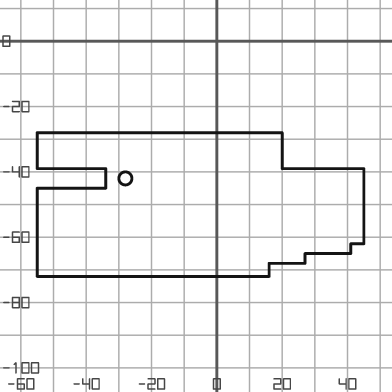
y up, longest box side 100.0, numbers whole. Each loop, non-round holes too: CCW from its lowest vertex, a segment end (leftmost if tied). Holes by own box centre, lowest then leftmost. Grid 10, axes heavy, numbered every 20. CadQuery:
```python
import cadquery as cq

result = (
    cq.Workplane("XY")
    .moveTo(-55.0, -72.0)
    .lineTo(16.0, -72.0)
    .lineTo(16.0, -68.0)
    .lineTo(27.0, -68.0)
    .lineTo(27.0, -65.0)
    .lineTo(41.0, -65.0)
    .lineTo(41.0, -62.0)
    .lineTo(45.0, -62.0)
    .lineTo(45.0, -39.0)
    .lineTo(20.0, -39.0)
    .lineTo(20.0, -28.0)
    .lineTo(-55.0, -28.0)
    .lineTo(-55.0, -39.0)
    .lineTo(-34.0, -39.0)
    .lineTo(-34.0, -45.0)
    .lineTo(-55.0, -45.0)
    .close()
    .moveTo(-28.0, -42.0)
    .circle(2.0)
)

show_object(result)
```